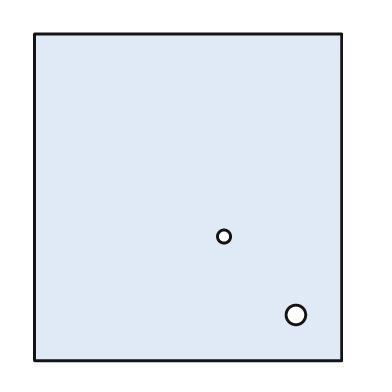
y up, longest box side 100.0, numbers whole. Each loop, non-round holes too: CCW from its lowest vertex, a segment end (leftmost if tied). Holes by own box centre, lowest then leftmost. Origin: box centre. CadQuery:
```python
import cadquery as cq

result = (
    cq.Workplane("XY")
    .moveTo(-47.0, -50.0)
    .lineTo(47.0, -50.0)
    .lineTo(47.0, 50.0)
    .lineTo(-47.0, 50.0)
    .close()
    .moveTo(33.0, -36.0)
    .circle(3.0)
    .moveTo(11.0, -12.0)
    .circle(2.0)
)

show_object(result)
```